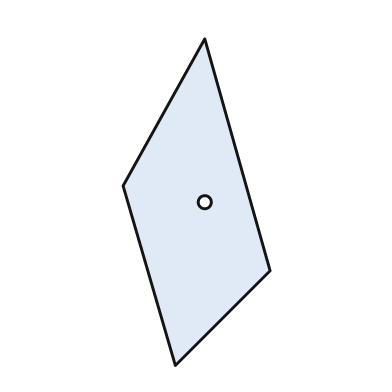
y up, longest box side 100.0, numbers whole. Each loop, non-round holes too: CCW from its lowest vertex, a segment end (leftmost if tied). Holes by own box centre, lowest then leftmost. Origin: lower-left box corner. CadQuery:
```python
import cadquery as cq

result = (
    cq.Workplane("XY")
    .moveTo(16.0, 0.0)
    .lineTo(45.0, 29.0)
    .lineTo(25.0, 100.0)
    .lineTo(0.0, 55.0)
    .close()
    .moveTo(25.0, 50.0)
    .circle(2.0)
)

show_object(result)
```